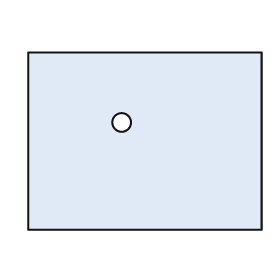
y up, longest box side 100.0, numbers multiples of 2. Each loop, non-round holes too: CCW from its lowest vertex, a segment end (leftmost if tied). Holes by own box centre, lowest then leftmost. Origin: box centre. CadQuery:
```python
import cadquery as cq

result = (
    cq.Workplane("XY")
    .moveTo(-50.0, -38.0)
    .lineTo(50.0, -38.0)
    .lineTo(50.0, 38.0)
    .lineTo(-50.0, 38.0)
    .close()
    .moveTo(-10.0, 8.0)
    .circle(4.0)
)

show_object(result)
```